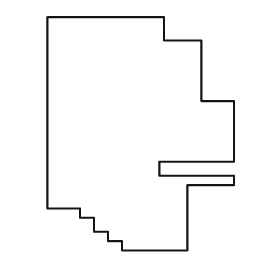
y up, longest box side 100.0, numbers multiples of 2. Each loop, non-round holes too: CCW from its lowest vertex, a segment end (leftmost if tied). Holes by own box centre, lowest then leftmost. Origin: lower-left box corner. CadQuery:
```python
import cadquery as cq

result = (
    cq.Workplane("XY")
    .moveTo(32.0, 0.0)
    .lineTo(60.0, 0.0)
    .lineTo(60.0, 28.0)
    .lineTo(80.0, 28.0)
    .lineTo(80.0, 32.0)
    .lineTo(48.0, 32.0)
    .lineTo(48.0, 38.0)
    .lineTo(80.0, 38.0)
    .lineTo(80.0, 64.0)
    .lineTo(66.0, 64.0)
    .lineTo(66.0, 90.0)
    .lineTo(50.0, 90.0)
    .lineTo(50.0, 100.0)
    .lineTo(0.0, 100.0)
    .lineTo(0.0, 18.0)
    .lineTo(14.0, 18.0)
    .lineTo(14.0, 14.0)
    .lineTo(20.0, 14.0)
    .lineTo(20.0, 8.0)
    .lineTo(26.0, 8.0)
    .lineTo(26.0, 4.0)
    .lineTo(32.0, 4.0)
    .close()
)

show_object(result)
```